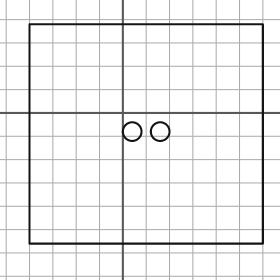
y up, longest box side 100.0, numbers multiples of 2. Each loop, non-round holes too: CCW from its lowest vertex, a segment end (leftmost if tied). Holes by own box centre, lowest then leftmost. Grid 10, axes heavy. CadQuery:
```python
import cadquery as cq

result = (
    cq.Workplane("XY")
    .moveTo(-40.0, -56.0)
    .lineTo(60.0, -56.0)
    .lineTo(60.0, 38.0)
    .lineTo(-40.0, 38.0)
    .close()
    .moveTo(4.0, -8.0)
    .circle(4.0)
    .moveTo(16.0, -8.0)
    .circle(4.0)
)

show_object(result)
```